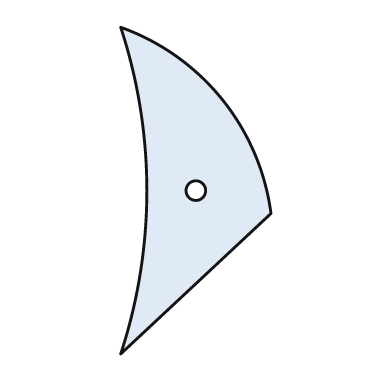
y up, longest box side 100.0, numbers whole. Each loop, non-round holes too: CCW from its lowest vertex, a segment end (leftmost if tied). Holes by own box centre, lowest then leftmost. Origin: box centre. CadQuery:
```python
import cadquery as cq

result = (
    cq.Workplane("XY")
    .moveTo(-23.0, -50.0)
    .lineTo(23.0, -7.0)
    .threePointArc((8.0, 28.0), (-23.0, 50.0))
    .threePointArc((-15.0, 0.0), (-23.0, -50.0))
    .close()
    .moveTo(0.0, 0.0)
    .circle(3.0)
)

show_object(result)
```